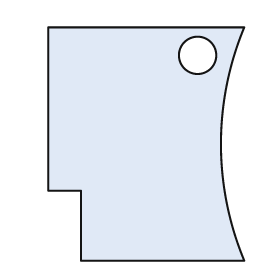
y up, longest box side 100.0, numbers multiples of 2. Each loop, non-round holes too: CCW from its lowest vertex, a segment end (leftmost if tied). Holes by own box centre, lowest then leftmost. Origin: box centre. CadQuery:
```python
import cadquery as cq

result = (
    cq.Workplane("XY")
    .moveTo(-28.0, -50.0)
    .lineTo(42.0, -50.0)
    .threePointArc((32.0, 0.0), (42.0, 50.0))
    .lineTo(-42.0, 50.0)
    .lineTo(-42.0, -20.0)
    .lineTo(-28.0, -20.0)
    .close()
    .moveTo(22.0, 38.0)
    .circle(8.0)
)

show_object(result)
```